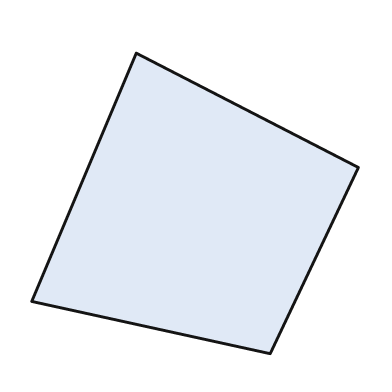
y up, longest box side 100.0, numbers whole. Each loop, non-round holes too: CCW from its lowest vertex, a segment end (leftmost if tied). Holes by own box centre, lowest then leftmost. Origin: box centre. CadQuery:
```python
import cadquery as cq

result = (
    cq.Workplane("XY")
    .moveTo(23.0, -46.0)
    .lineTo(50.0, 11.0)
    .lineTo(-18.0, 46.0)
    .lineTo(-50.0, -30.0)
    .close()
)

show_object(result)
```